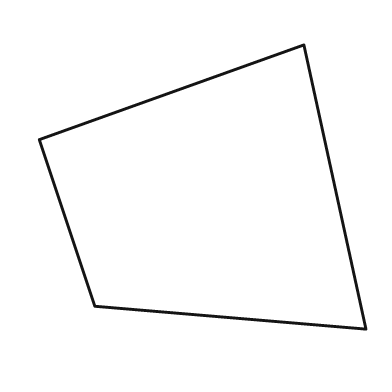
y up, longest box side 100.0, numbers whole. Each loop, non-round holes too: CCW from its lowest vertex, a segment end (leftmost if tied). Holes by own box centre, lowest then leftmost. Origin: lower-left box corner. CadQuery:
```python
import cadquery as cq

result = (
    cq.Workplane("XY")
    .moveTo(100.0, 0.0)
    .lineTo(81.0, 87.0)
    .lineTo(0.0, 58.0)
    .lineTo(17.0, 7.0)
    .close()
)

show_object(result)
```